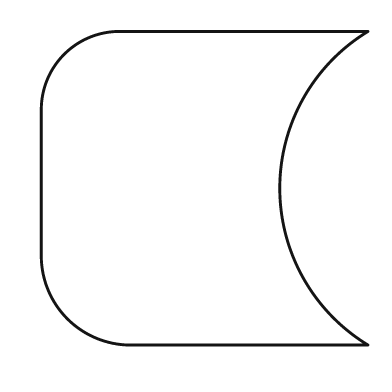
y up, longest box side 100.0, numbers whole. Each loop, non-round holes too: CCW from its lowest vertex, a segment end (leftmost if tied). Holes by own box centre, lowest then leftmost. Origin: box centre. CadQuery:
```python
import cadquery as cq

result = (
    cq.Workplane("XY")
    .moveTo(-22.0, -48.0)
    .lineTo(50.0, -48.0)
    .threePointArc((23.0, 0.0), (50.0, 48.0))
    .lineTo(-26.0, 48.0)
    .threePointArc((-43.0, 41.0), (-50.0, 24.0))
    .lineTo(-50.0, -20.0)
    .threePointArc((-42.0, -40.0), (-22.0, -48.0))
    .close()
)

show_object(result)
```